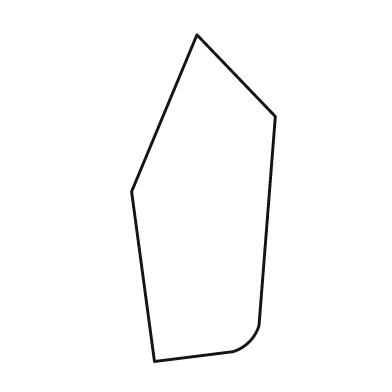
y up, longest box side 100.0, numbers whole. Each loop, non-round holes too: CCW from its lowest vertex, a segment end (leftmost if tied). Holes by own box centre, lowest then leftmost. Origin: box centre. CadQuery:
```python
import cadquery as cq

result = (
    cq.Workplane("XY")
    .moveTo(-15.0, -50.0)
    .lineTo(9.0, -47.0)
    .threePointArc((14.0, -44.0), (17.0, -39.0))
    .lineTo(22.0, 25.0)
    .lineTo(-2.0, 50.0)
    .lineTo(-22.0, 2.0)
    .close()
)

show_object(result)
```